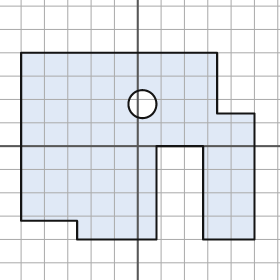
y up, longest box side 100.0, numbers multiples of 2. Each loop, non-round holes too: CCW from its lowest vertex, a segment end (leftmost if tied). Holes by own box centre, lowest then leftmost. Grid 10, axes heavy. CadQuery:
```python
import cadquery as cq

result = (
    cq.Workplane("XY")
    .moveTo(-26.0, -40.0)
    .lineTo(8.0, -40.0)
    .lineTo(8.0, 0.0)
    .lineTo(28.0, 0.0)
    .lineTo(28.0, -40.0)
    .lineTo(50.0, -40.0)
    .lineTo(50.0, 14.0)
    .lineTo(34.0, 14.0)
    .lineTo(34.0, 40.0)
    .lineTo(-50.0, 40.0)
    .lineTo(-50.0, -32.0)
    .lineTo(-26.0, -32.0)
    .close()
    .moveTo(2.0, 18.0)
    .circle(6.0)
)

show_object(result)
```